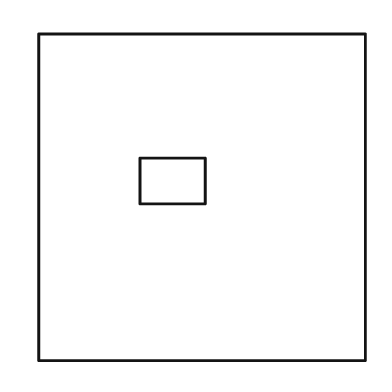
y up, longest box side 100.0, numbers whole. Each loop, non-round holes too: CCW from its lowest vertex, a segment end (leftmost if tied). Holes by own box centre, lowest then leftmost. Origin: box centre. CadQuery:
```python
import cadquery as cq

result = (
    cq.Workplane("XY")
    .moveTo(-50.0, -50.0)
    .lineTo(50.0, -50.0)
    .lineTo(50.0, 50.0)
    .lineTo(-50.0, 50.0)
    .close()
    .moveTo(-19.0, -2.0)
    .lineTo(1.0, -2.0)
    .lineTo(1.0, 12.0)
    .lineTo(-19.0, 12.0)
    .close()
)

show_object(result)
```